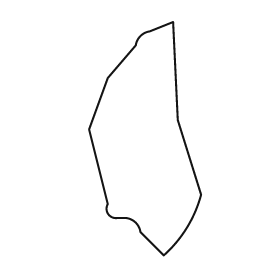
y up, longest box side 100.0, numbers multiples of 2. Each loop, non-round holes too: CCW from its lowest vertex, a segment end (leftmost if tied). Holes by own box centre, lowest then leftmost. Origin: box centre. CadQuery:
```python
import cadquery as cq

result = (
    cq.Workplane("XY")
    .moveTo(8.0, -50.0)
    .threePointArc((18.0, -38.0), (24.0, -24.0))
    .lineTo(14.0, 8.0)
    .lineTo(12.0, 50.0)
    .lineTo(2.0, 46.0)
    .threePointArc((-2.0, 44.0), (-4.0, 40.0))
    .lineTo(-16.0, 26.0)
    .lineTo(-24.0, 4.0)
    .lineTo(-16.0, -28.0)
    .threePointArc((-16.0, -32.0), (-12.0, -34.0))
    .lineTo(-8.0, -34.0)
    .threePointArc((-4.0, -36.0), (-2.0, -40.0))
    .close()
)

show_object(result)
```